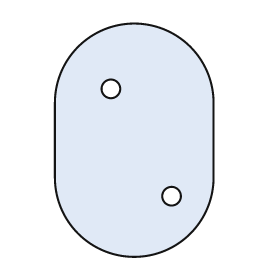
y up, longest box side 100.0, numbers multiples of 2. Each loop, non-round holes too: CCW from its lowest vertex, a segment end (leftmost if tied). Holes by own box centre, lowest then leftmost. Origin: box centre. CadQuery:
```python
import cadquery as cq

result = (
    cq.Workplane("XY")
    .moveTo(-34.0, -16.0)
    .threePointArc((0.0, -50.0), (34.0, -16.0))
    .lineTo(34.0, 16.0)
    .threePointArc((0.0, 50.0), (-34.0, 16.0))
    .close()
    .moveTo(16.0, -24.0)
    .circle(4.0)
    .moveTo(-10.0, 22.0)
    .circle(4.0)
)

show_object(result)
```